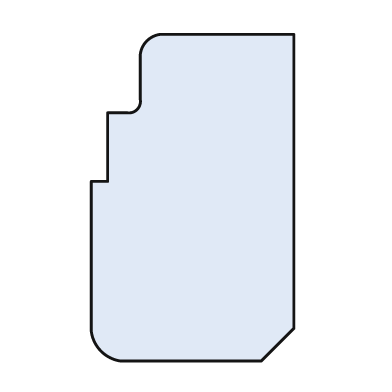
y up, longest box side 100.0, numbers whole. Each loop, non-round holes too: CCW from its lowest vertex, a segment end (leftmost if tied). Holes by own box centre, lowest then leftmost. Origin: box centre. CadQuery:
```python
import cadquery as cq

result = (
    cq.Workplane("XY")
    .moveTo(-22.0, -50.0)
    .lineTo(21.0, -50.0)
    .lineTo(31.0, -40.0)
    .lineTo(31.0, 50.0)
    .lineTo(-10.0, 50.0)
    .threePointArc((-14.0, 48.0), (-16.0, 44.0))
    .lineTo(-16.0, 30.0)
    .threePointArc((-17.0, 27.0), (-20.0, 26.0))
    .lineTo(-26.0, 26.0)
    .lineTo(-26.0, 5.0)
    .lineTo(-31.0, 5.0)
    .lineTo(-31.0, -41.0)
    .threePointArc((-28.0, -47.0), (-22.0, -50.0))
    .close()
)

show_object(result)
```